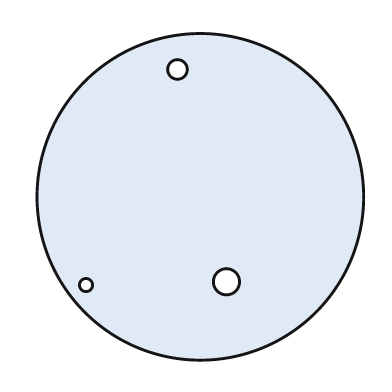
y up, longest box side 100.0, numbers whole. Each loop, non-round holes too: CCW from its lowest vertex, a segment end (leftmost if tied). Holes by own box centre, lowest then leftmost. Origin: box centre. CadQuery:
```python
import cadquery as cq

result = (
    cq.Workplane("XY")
    .moveTo(0.0, 0.0)
    .circle(50.0)
    .moveTo(-35.0, -27.0)
    .circle(2.0)
    .moveTo(8.0, -26.0)
    .circle(4.0)
    .moveTo(-7.0, 39.0)
    .circle(3.0)
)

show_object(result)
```